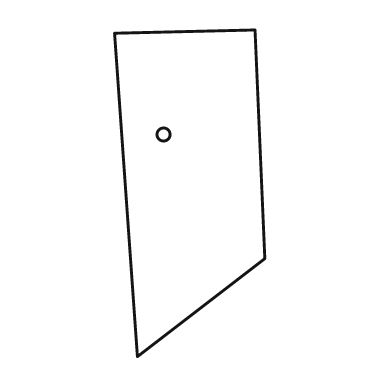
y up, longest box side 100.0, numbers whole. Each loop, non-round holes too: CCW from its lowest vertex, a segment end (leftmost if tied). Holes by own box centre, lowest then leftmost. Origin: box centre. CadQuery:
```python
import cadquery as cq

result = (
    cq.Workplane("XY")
    .moveTo(-16.0, -50.0)
    .lineTo(23.0, -20.0)
    .lineTo(20.0, 50.0)
    .lineTo(-23.0, 49.0)
    .close()
    .moveTo(-8.0, 18.0)
    .circle(2.0)
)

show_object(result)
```